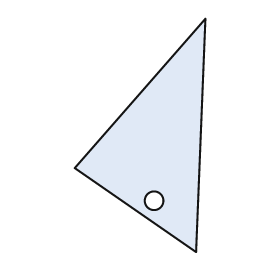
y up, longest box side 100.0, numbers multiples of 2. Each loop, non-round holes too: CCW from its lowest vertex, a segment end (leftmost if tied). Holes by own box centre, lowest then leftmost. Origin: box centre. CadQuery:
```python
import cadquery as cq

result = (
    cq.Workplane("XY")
    .moveTo(24.0, -50.0)
    .lineTo(28.0, 50.0)
    .lineTo(-28.0, -14.0)
    .close()
    .moveTo(6.0, -28.0)
    .circle(4.0)
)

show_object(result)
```